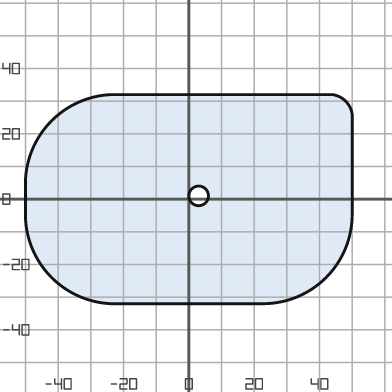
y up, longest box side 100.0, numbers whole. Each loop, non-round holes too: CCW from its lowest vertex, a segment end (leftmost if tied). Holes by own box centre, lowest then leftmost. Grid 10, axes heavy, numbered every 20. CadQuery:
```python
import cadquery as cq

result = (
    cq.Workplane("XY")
    .moveTo(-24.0, -32.0)
    .lineTo(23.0, -32.0)
    .threePointArc((42.0, -24.0), (50.0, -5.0))
    .lineTo(50.0, 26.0)
    .threePointArc((48.0, 30.0), (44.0, 32.0))
    .lineTo(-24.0, 32.0)
    .threePointArc((-42.0, 24.0), (-50.0, 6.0))
    .lineTo(-50.0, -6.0)
    .threePointArc((-42.0, -24.0), (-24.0, -32.0))
    .close()
    .moveTo(3.0, 1.0)
    .circle(3.0)
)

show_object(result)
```